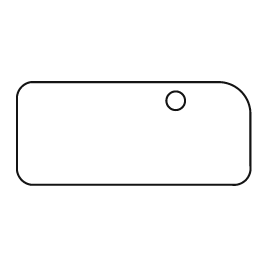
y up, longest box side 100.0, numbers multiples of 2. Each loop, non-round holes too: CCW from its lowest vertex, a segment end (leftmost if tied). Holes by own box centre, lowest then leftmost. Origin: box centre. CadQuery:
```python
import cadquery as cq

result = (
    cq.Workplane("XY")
    .moveTo(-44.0, -22.0)
    .lineTo(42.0, -22.0)
    .threePointArc((48.0, -20.0), (50.0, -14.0))
    .lineTo(50.0, 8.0)
    .threePointArc((46.0, 18.0), (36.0, 22.0))
    .lineTo(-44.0, 22.0)
    .threePointArc((-48.0, 20.0), (-50.0, 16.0))
    .lineTo(-50.0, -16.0)
    .threePointArc((-48.0, -20.0), (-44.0, -22.0))
    .close()
    .moveTo(18.0, 14.0)
    .circle(4.0)
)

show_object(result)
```